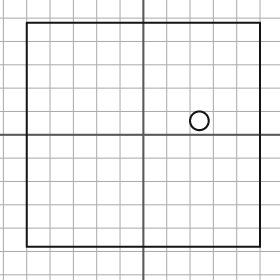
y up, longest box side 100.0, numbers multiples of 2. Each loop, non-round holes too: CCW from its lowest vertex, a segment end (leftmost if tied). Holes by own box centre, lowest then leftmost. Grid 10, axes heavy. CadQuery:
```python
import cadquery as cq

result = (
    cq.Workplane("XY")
    .moveTo(-50.0, -48.0)
    .lineTo(50.0, -48.0)
    .lineTo(50.0, 48.0)
    .lineTo(-50.0, 48.0)
    .close()
    .moveTo(24.0, 6.0)
    .circle(4.0)
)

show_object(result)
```